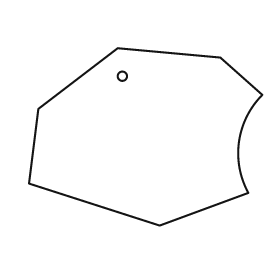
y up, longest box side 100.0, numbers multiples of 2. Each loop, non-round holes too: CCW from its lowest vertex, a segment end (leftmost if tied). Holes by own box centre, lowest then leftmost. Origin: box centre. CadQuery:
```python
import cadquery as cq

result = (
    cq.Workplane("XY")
    .moveTo(6.0, -38.0)
    .lineTo(44.0, -24.0)
    .threePointArc((40.0, -2.0), (50.0, 18.0))
    .lineTo(32.0, 34.0)
    .lineTo(-12.0, 38.0)
    .lineTo(-46.0, 12.0)
    .lineTo(-50.0, -20.0)
    .close()
    .moveTo(-10.0, 26.0)
    .circle(2.0)
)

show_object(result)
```